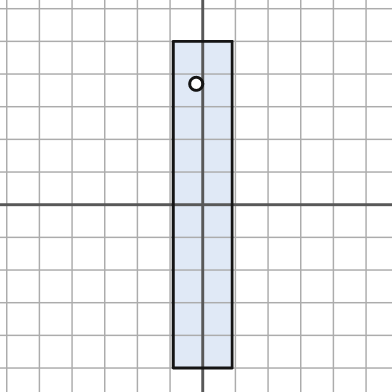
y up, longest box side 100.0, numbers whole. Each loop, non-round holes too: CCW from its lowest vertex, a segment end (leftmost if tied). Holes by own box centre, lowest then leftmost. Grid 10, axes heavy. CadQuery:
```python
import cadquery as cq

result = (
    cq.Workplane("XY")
    .moveTo(-9.0, -50.0)
    .lineTo(9.0, -50.0)
    .lineTo(9.0, 50.0)
    .lineTo(-9.0, 50.0)
    .close()
    .moveTo(-2.0, 37.0)
    .circle(2.0)
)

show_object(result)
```